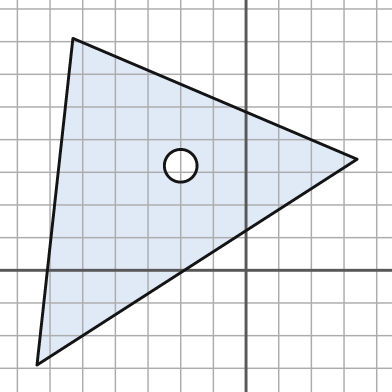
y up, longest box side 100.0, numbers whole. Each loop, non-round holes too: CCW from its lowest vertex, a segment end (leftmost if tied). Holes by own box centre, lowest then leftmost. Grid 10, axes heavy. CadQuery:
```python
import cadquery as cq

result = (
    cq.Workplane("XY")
    .moveTo(-64.0, -29.0)
    .lineTo(34.0, 34.0)
    .lineTo(-53.0, 71.0)
    .close()
    .moveTo(-20.0, 32.0)
    .circle(5.0)
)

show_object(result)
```